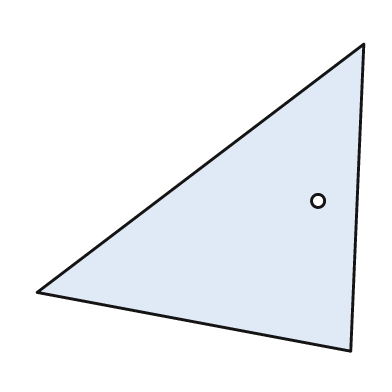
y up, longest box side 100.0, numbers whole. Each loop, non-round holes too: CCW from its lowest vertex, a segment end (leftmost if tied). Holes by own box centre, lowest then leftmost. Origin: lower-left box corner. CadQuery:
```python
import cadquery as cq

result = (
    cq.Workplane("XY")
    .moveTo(96.0, 0.0)
    .lineTo(100.0, 94.0)
    .lineTo(0.0, 18.0)
    .close()
    .moveTo(86.0, 46.0)
    .circle(2.0)
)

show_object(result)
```